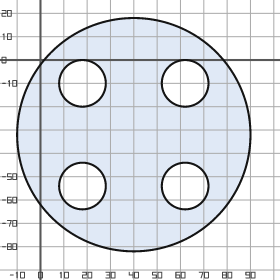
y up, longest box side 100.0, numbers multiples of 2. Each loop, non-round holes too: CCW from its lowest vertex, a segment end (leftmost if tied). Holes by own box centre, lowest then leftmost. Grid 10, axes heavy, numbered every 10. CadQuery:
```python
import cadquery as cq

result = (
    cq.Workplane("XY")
    .moveTo(40.0, -32.0)
    .circle(50.0)
    .moveTo(18.0, -54.0)
    .circle(10.0)
    .moveTo(62.0, -54.0)
    .circle(10.0)
    .moveTo(18.0, -10.0)
    .circle(10.0)
    .moveTo(62.0, -10.0)
    .circle(10.0)
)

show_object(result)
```